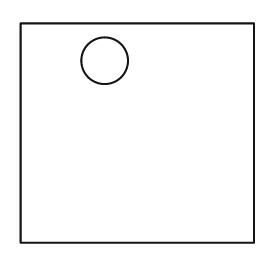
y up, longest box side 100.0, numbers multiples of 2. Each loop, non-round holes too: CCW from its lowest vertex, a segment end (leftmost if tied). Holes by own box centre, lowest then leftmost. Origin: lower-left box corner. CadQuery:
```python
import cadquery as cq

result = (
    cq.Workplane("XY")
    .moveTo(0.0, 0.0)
    .lineTo(100.0, 0.0)
    .lineTo(100.0, 94.0)
    .lineTo(0.0, 94.0)
    .close()
    .moveTo(36.0, 78.0)
    .circle(10.0)
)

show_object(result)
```